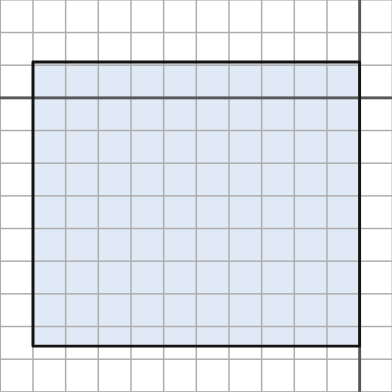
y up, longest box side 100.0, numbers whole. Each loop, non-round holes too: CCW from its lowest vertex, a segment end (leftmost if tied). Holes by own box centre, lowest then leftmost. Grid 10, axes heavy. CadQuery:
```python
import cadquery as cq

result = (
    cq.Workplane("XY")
    .moveTo(-100.0, -76.0)
    .lineTo(0.0, -76.0)
    .lineTo(0.0, 11.0)
    .lineTo(-100.0, 11.0)
    .close()
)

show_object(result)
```